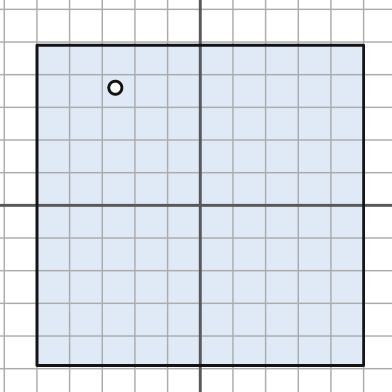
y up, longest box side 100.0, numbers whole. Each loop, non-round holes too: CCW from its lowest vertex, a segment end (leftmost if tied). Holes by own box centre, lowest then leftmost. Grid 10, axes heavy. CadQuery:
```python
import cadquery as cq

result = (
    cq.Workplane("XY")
    .moveTo(-50.0, -49.0)
    .lineTo(50.0, -49.0)
    .lineTo(50.0, 49.0)
    .lineTo(-50.0, 49.0)
    .close()
    .moveTo(-26.0, 36.0)
    .circle(2.0)
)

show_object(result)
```